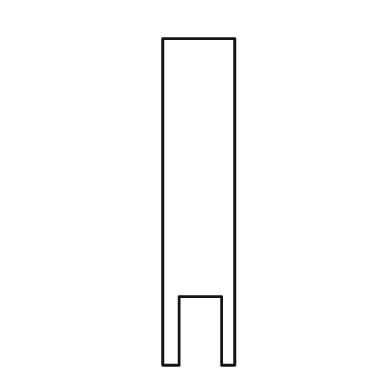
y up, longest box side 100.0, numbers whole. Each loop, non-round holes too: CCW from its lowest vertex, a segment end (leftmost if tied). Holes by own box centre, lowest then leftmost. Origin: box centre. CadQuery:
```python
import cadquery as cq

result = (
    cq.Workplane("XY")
    .moveTo(-11.0, -50.0)
    .lineTo(-6.0, -50.0)
    .lineTo(-6.0, -29.0)
    .lineTo(7.0, -29.0)
    .lineTo(7.0, -50.0)
    .lineTo(11.0, -50.0)
    .lineTo(11.0, 50.0)
    .lineTo(-11.0, 50.0)
    .close()
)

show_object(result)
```